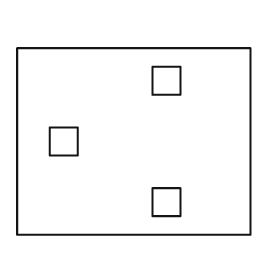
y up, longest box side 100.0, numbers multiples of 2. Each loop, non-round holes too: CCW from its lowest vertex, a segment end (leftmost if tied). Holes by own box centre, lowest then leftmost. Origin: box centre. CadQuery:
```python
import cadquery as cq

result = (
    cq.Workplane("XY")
    .moveTo(-50.0, -40.0)
    .lineTo(50.0, -40.0)
    .lineTo(50.0, 40.0)
    .lineTo(-50.0, 40.0)
    .close()
    .moveTo(8.0, -32.0)
    .lineTo(20.0, -32.0)
    .lineTo(20.0, -20.0)
    .lineTo(8.0, -20.0)
    .close()
    .moveTo(-36.0, -6.0)
    .lineTo(-24.0, -6.0)
    .lineTo(-24.0, 6.0)
    .lineTo(-36.0, 6.0)
    .close()
    .moveTo(8.0, 20.0)
    .lineTo(20.0, 20.0)
    .lineTo(20.0, 32.0)
    .lineTo(8.0, 32.0)
    .close()
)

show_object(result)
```